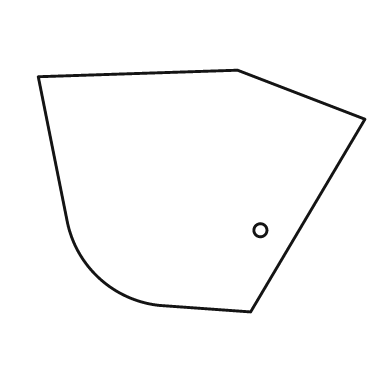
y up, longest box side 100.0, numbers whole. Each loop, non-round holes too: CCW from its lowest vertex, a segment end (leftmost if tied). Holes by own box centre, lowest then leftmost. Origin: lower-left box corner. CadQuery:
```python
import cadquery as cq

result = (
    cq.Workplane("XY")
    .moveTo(65.0, 0.0)
    .lineTo(100.0, 59.0)
    .lineTo(61.0, 74.0)
    .lineTo(0.0, 72.0)
    .lineTo(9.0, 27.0)
    .threePointArc((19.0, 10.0), (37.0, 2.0))
    .close()
    .moveTo(68.0, 25.0)
    .circle(2.0)
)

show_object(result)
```